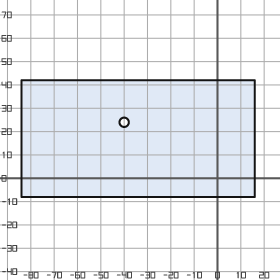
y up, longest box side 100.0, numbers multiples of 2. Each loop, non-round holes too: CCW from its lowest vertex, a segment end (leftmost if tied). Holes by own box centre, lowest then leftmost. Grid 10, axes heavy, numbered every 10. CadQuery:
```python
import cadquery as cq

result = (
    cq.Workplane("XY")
    .moveTo(-84.0, -8.0)
    .lineTo(16.0, -8.0)
    .lineTo(16.0, 42.0)
    .lineTo(-84.0, 42.0)
    .close()
    .moveTo(-40.0, 24.0)
    .circle(2.0)
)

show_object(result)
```